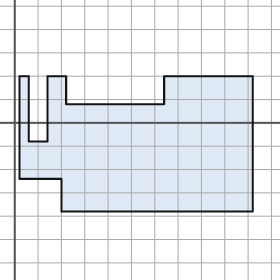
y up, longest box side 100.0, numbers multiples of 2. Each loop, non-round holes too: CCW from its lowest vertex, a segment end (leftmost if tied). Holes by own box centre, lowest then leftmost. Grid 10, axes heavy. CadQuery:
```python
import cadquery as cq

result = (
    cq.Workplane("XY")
    .moveTo(20.0, -38.0)
    .lineTo(102.0, -38.0)
    .lineTo(102.0, 20.0)
    .lineTo(64.0, 20.0)
    .lineTo(64.0, 8.0)
    .lineTo(22.0, 8.0)
    .lineTo(22.0, 20.0)
    .lineTo(14.0, 20.0)
    .lineTo(14.0, -8.0)
    .lineTo(6.0, -8.0)
    .lineTo(6.0, 20.0)
    .lineTo(2.0, 20.0)
    .lineTo(2.0, -24.0)
    .lineTo(20.0, -24.0)
    .close()
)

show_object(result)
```